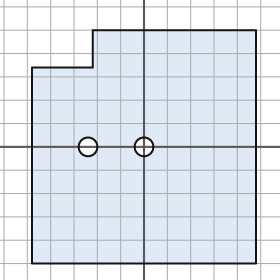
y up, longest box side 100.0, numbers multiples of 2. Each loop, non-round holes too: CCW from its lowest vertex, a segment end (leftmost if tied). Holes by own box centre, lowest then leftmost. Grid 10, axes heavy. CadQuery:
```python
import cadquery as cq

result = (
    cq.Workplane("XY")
    .moveTo(-48.0, -50.0)
    .lineTo(48.0, -50.0)
    .lineTo(48.0, 50.0)
    .lineTo(-22.0, 50.0)
    .lineTo(-22.0, 34.0)
    .lineTo(-48.0, 34.0)
    .close()
    .moveTo(-24.0, 0.0)
    .circle(4.0)
    .moveTo(0.0, 0.0)
    .circle(4.0)
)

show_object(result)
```